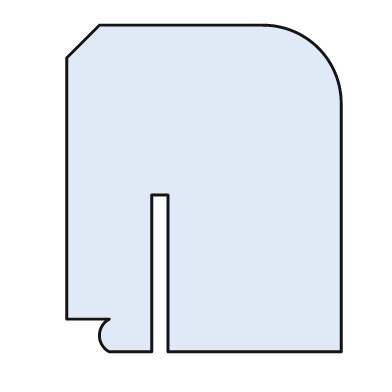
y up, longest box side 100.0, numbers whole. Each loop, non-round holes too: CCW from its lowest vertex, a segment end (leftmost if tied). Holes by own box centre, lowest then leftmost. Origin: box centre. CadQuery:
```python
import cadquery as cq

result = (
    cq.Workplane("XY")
    .moveTo(-29.0, -50.0)
    .lineTo(-16.0, -50.0)
    .lineTo(-16.0, -2.0)
    .lineTo(-11.0, -2.0)
    .lineTo(-11.0, -50.0)
    .lineTo(42.0, -50.0)
    .lineTo(42.0, 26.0)
    .threePointArc((35.0, 43.0), (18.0, 50.0))
    .lineTo(-32.0, 50.0)
    .lineTo(-42.0, 40.0)
    .lineTo(-42.0, -40.0)
    .lineTo(-29.0, -40.0)
    .threePointArc((-32.0, -45.0), (-29.0, -50.0))
    .close()
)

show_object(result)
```